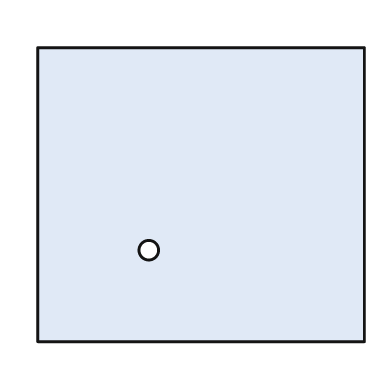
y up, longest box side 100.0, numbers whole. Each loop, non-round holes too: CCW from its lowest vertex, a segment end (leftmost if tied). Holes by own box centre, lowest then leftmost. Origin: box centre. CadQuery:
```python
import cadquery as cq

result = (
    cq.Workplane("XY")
    .moveTo(-50.0, -45.0)
    .lineTo(50.0, -45.0)
    .lineTo(50.0, 45.0)
    .lineTo(-50.0, 45.0)
    .close()
    .moveTo(-16.0, -17.0)
    .circle(3.0)
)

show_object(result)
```